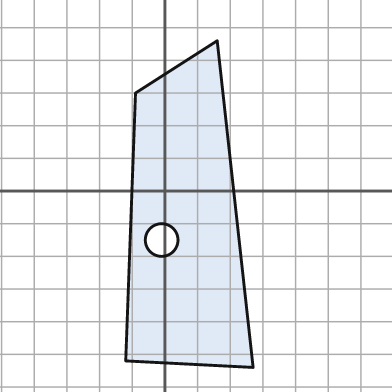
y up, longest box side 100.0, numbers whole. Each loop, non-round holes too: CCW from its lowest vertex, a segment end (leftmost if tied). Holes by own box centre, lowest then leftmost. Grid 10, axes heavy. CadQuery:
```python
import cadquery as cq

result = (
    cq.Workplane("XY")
    .moveTo(27.0, -54.0)
    .lineTo(16.0, 46.0)
    .lineTo(-9.0, 30.0)
    .lineTo(-12.0, -52.0)
    .close()
    .moveTo(-1.0, -15.0)
    .circle(5.0)
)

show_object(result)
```